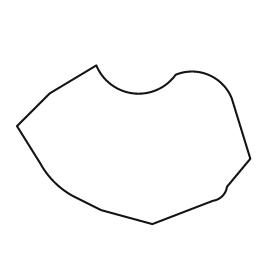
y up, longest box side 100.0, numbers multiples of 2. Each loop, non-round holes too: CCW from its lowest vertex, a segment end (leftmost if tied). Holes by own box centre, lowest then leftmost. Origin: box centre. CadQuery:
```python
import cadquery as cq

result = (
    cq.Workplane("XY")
    .moveTo(8.0, -34.0)
    .lineTo(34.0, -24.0)
    .threePointArc((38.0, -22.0), (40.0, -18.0))
    .lineTo(50.0, -6.0)
    .lineTo(42.0, 20.0)
    .threePointArc((32.0, 30.0), (18.0, 30.0))
    .threePointArc((0.0, 22.0), (-16.0, 34.0))
    .lineTo(-36.0, 22.0)
    .lineTo(-50.0, 8.0)
    .lineTo(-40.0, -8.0)
    .threePointArc((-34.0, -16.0), (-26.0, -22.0))
    .lineTo(-14.0, -28.0)
    .close()
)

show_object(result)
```